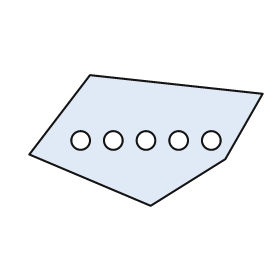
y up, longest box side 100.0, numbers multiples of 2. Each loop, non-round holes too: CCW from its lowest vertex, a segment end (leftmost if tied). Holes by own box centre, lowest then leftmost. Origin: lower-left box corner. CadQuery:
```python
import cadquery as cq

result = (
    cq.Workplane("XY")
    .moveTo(52.0, 0.0)
    .lineTo(84.0, 20.0)
    .lineTo(100.0, 48.0)
    .lineTo(26.0, 56.0)
    .lineTo(0.0, 22.0)
    .close()
    .moveTo(22.0, 28.0)
    .circle(4.0)
    .moveTo(36.0, 28.0)
    .circle(4.0)
    .moveTo(50.0, 28.0)
    .circle(4.0)
    .moveTo(64.0, 28.0)
    .circle(4.0)
    .moveTo(78.0, 28.0)
    .circle(4.0)
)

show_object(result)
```